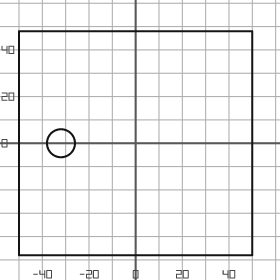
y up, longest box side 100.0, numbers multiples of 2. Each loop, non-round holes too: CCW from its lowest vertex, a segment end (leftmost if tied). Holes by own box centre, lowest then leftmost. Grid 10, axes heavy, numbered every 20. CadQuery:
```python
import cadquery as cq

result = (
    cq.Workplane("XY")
    .moveTo(-50.0, -48.0)
    .lineTo(50.0, -48.0)
    .lineTo(50.0, 48.0)
    .lineTo(-50.0, 48.0)
    .close()
    .moveTo(-32.0, 0.0)
    .circle(6.0)
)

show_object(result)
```